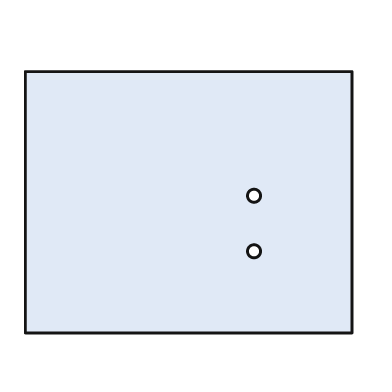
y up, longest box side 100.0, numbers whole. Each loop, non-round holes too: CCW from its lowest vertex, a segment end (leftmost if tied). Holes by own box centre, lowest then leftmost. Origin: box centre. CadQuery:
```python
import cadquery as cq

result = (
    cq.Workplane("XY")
    .moveTo(-50.0, -40.0)
    .lineTo(50.0, -40.0)
    .lineTo(50.0, 40.0)
    .lineTo(-50.0, 40.0)
    .close()
    .moveTo(20.0, -15.0)
    .circle(2.0)
    .moveTo(20.0, 2.0)
    .circle(2.0)
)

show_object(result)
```